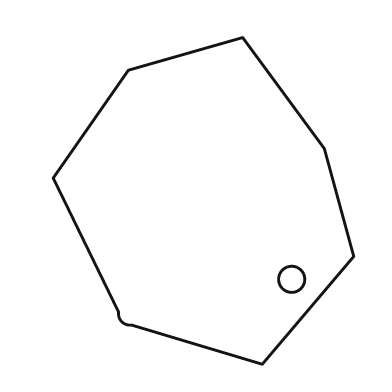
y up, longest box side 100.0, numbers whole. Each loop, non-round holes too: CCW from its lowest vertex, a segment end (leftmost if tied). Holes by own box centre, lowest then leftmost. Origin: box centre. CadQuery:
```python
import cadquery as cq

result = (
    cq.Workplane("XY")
    .moveTo(18.0, -50.0)
    .lineTo(46.0, -17.0)
    .lineTo(37.0, 16.0)
    .lineTo(12.0, 50.0)
    .lineTo(-23.0, 40.0)
    .lineTo(-46.0, 7.0)
    .lineTo(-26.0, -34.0)
    .threePointArc((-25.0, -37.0), (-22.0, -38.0))
    .close()
    .moveTo(27.0, -24.0)
    .circle(4.0)
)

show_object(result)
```